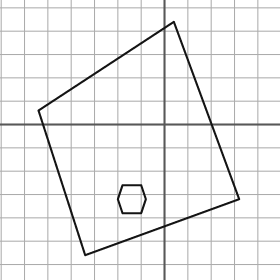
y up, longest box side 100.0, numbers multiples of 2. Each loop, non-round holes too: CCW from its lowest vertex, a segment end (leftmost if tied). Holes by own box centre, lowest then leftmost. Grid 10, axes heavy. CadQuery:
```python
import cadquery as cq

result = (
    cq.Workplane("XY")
    .moveTo(-34.0, -56.0)
    .lineTo(32.0, -32.0)
    .lineTo(4.0, 44.0)
    .lineTo(-54.0, 6.0)
    .close()
    .moveTo(-18.0, -38.0)
    .lineTo(-10.0, -38.0)
    .lineTo(-8.0, -32.0)
    .lineTo(-10.0, -26.0)
    .lineTo(-18.0, -26.0)
    .lineTo(-20.0, -32.0)
    .close()
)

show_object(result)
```